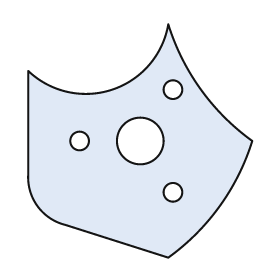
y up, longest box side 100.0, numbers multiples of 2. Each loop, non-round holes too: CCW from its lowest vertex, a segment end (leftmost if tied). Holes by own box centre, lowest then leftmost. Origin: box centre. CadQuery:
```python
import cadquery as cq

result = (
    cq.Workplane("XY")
    .moveTo(12.0, -50.0)
    .threePointArc((34.0, -28.0), (48.0, 0.0))
    .threePointArc((26.0, 22.0), (12.0, 50.0))
    .threePointArc((-12.0, 22.0), (-48.0, 30.0))
    .lineTo(-48.0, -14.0)
    .threePointArc((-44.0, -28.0), (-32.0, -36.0))
    .close()
    .moveTo(14.0, -22.0)
    .circle(4.0)
    .moveTo(-26.0, 0.0)
    .circle(4.0)
    .moveTo(0.0, 0.0)
    .circle(10.0)
    .moveTo(14.0, 22.0)
    .circle(4.0)
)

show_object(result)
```